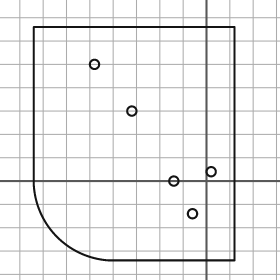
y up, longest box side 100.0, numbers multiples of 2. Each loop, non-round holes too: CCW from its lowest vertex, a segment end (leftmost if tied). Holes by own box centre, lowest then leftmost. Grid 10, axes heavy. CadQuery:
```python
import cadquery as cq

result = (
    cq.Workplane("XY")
    .moveTo(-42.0, -34.0)
    .lineTo(12.0, -34.0)
    .lineTo(12.0, 66.0)
    .lineTo(-74.0, 66.0)
    .lineTo(-74.0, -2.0)
    .threePointArc((-64.0, -24.0), (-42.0, -34.0))
    .close()
    .moveTo(-6.0, -14.0)
    .circle(2.0)
    .moveTo(-14.0, 0.0)
    .circle(2.0)
    .moveTo(2.0, 4.0)
    .circle(2.0)
    .moveTo(-32.0, 30.0)
    .circle(2.0)
    .moveTo(-48.0, 50.0)
    .circle(2.0)
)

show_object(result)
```